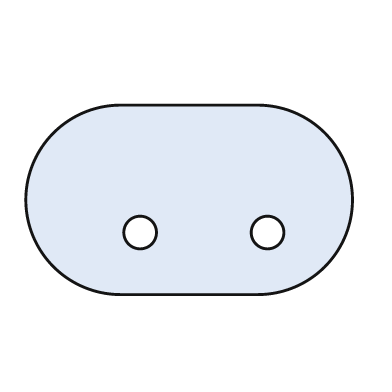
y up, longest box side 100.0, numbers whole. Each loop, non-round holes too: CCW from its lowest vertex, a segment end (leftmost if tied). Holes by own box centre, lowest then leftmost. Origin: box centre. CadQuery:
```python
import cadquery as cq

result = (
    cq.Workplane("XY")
    .moveTo(-21.0, -29.0)
    .lineTo(21.0, -29.0)
    .threePointArc((50.0, 0.0), (21.0, 29.0))
    .lineTo(-21.0, 29.0)
    .threePointArc((-50.0, 0.0), (-21.0, -29.0))
    .close()
    .moveTo(-15.0, -10.0)
    .circle(5.0)
    .moveTo(24.0, -10.0)
    .circle(5.0)
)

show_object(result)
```